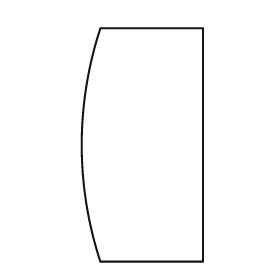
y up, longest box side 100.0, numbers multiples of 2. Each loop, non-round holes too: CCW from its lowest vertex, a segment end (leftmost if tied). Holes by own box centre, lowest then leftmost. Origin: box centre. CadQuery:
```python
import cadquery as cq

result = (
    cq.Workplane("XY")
    .moveTo(-18.0, -50.0)
    .lineTo(26.0, -50.0)
    .lineTo(26.0, 50.0)
    .lineTo(-18.0, 50.0)
    .threePointArc((-26.0, 0.0), (-18.0, -50.0))
    .close()
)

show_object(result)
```